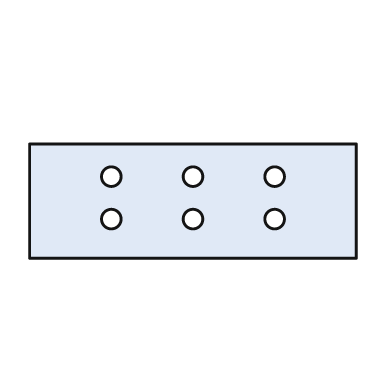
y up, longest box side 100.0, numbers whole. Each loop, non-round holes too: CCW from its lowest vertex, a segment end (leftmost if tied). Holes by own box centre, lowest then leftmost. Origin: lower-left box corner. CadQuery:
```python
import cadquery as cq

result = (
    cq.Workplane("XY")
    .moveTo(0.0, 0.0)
    .lineTo(100.0, 0.0)
    .lineTo(100.0, 35.0)
    .lineTo(0.0, 35.0)
    .close()
    .moveTo(25.0, 12.0)
    .circle(3.0)
    .moveTo(50.0, 12.0)
    .circle(3.0)
    .moveTo(75.0, 12.0)
    .circle(3.0)
    .moveTo(25.0, 25.0)
    .circle(3.0)
    .moveTo(50.0, 25.0)
    .circle(3.0)
    .moveTo(75.0, 25.0)
    .circle(3.0)
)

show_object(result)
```